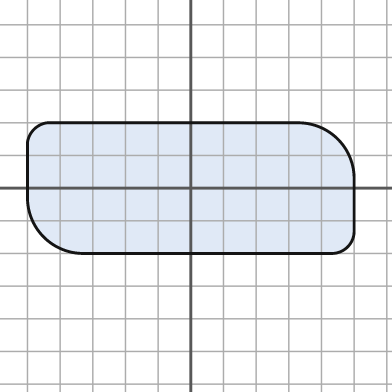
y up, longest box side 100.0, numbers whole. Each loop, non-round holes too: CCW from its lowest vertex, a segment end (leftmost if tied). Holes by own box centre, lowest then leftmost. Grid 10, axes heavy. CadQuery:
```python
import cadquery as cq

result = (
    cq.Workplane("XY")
    .moveTo(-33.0, -20.0)
    .lineTo(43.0, -20.0)
    .threePointArc((48.0, -18.0), (50.0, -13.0))
    .lineTo(50.0, 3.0)
    .threePointArc((45.0, 15.0), (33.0, 20.0))
    .lineTo(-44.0, 20.0)
    .threePointArc((-48.0, 18.0), (-50.0, 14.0))
    .lineTo(-50.0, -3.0)
    .threePointArc((-45.0, -15.0), (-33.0, -20.0))
    .close()
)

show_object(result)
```